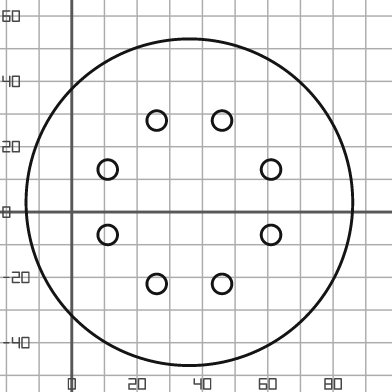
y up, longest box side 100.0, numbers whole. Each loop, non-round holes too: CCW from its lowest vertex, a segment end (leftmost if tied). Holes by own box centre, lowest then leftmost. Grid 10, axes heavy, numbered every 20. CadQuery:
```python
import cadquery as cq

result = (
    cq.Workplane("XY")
    .moveTo(36.0, 3.0)
    .circle(50.0)
    .moveTo(26.0, -22.0)
    .circle(3.0)
    .moveTo(46.0, -22.0)
    .circle(3.0)
    .moveTo(11.0, -7.0)
    .circle(3.0)
    .moveTo(61.0, -7.0)
    .circle(3.0)
    .moveTo(11.0, 13.0)
    .circle(3.0)
    .moveTo(61.0, 13.0)
    .circle(3.0)
    .moveTo(26.0, 28.0)
    .circle(3.0)
    .moveTo(46.0, 28.0)
    .circle(3.0)
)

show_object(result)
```